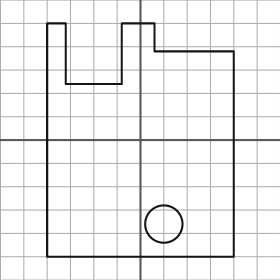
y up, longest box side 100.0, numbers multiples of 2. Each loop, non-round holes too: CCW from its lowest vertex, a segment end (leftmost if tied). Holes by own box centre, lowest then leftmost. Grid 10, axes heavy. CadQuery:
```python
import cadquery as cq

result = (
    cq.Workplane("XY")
    .moveTo(-40.0, -50.0)
    .lineTo(40.0, -50.0)
    .lineTo(40.0, 38.0)
    .lineTo(6.0, 38.0)
    .lineTo(6.0, 50.0)
    .lineTo(-8.0, 50.0)
    .lineTo(-8.0, 24.0)
    .lineTo(-32.0, 24.0)
    .lineTo(-32.0, 50.0)
    .lineTo(-40.0, 50.0)
    .close()
    .moveTo(10.0, -36.0)
    .circle(8.0)
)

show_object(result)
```